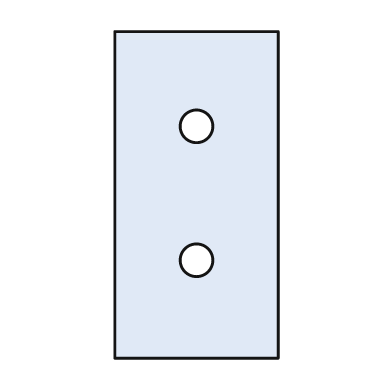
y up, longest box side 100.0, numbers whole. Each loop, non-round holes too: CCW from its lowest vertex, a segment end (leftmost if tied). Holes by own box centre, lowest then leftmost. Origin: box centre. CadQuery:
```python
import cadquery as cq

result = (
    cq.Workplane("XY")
    .moveTo(-25.0, -50.0)
    .lineTo(25.0, -50.0)
    .lineTo(25.0, 50.0)
    .lineTo(-25.0, 50.0)
    .close()
    .moveTo(0.0, -20.0)
    .circle(5.0)
    .moveTo(0.0, 21.0)
    .circle(5.0)
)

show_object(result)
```